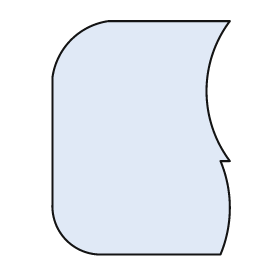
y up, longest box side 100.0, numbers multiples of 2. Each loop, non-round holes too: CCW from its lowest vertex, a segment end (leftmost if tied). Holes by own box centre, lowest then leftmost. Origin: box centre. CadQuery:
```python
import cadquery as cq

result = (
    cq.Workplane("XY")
    .moveTo(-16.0, -50.0)
    .lineTo(34.0, -50.0)
    .threePointArc((38.0, -30.0), (34.0, -10.0))
    .lineTo(38.0, -10.0)
    .threePointArc((28.0, 20.0), (38.0, 50.0))
    .lineTo(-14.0, 50.0)
    .threePointArc((-30.0, 42.0), (-38.0, 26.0))
    .lineTo(-38.0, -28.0)
    .threePointArc((-32.0, -44.0), (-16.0, -50.0))
    .close()
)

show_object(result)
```